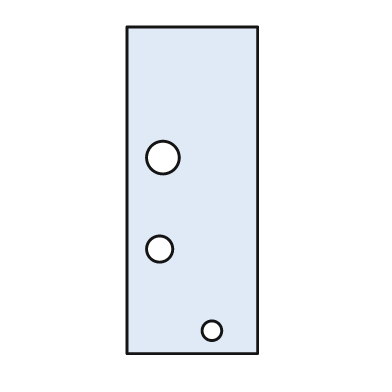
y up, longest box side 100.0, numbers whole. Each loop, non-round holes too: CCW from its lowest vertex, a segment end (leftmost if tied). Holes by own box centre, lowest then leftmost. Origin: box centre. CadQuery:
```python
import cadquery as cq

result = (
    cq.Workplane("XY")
    .moveTo(-20.0, -50.0)
    .lineTo(20.0, -50.0)
    .lineTo(20.0, 50.0)
    .lineTo(-20.0, 50.0)
    .close()
    .moveTo(6.0, -43.0)
    .circle(3.0)
    .moveTo(-10.0, -18.0)
    .circle(4.0)
    .moveTo(-9.0, 10.0)
    .circle(5.0)
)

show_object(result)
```